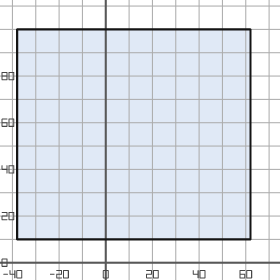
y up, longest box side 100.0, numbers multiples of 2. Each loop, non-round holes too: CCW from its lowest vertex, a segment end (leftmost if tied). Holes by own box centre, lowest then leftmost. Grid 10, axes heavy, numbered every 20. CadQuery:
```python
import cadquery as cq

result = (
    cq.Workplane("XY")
    .moveTo(-38.0, 10.0)
    .lineTo(62.0, 10.0)
    .lineTo(62.0, 100.0)
    .lineTo(-38.0, 100.0)
    .close()
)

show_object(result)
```